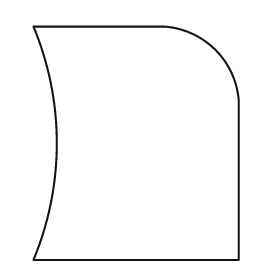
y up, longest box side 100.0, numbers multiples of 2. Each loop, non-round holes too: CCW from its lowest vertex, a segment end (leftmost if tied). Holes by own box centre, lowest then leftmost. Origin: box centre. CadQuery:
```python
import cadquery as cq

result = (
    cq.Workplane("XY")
    .moveTo(-44.0, -50.0)
    .lineTo(44.0, -50.0)
    .lineTo(44.0, 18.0)
    .threePointArc((34.0, 40.0), (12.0, 50.0))
    .lineTo(-44.0, 50.0)
    .threePointArc((-34.0, 0.0), (-44.0, -50.0))
    .close()
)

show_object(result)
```